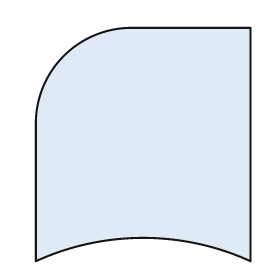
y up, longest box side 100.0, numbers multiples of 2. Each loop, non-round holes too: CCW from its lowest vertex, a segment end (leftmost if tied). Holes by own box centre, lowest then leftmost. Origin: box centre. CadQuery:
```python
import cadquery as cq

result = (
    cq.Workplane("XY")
    .moveTo(-46.0, -50.0)
    .threePointArc((0.0, -40.0), (46.0, -50.0))
    .lineTo(46.0, 50.0)
    .lineTo(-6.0, 50.0)
    .threePointArc((-34.0, 38.0), (-46.0, 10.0))
    .close()
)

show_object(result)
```